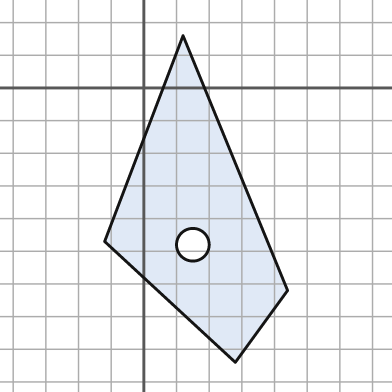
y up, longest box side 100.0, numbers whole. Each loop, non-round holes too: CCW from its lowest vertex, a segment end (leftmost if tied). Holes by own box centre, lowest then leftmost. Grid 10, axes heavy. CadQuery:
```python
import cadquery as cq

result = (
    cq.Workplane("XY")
    .moveTo(28.0, -84.0)
    .lineTo(44.0, -62.0)
    .lineTo(12.0, 16.0)
    .lineTo(-12.0, -47.0)
    .close()
    .moveTo(15.0, -48.0)
    .circle(5.0)
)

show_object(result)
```